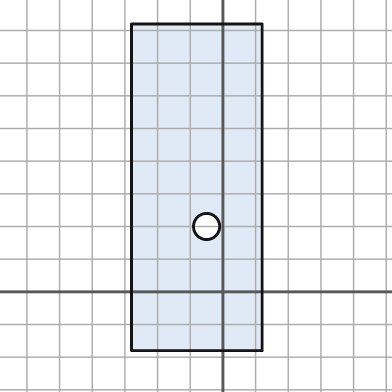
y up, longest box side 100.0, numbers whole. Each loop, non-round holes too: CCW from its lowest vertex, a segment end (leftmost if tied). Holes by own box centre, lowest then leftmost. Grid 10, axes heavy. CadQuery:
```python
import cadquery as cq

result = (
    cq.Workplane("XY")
    .moveTo(-28.0, -18.0)
    .lineTo(12.0, -18.0)
    .lineTo(12.0, 82.0)
    .lineTo(-28.0, 82.0)
    .close()
    .moveTo(-5.0, 20.0)
    .circle(4.0)
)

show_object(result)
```